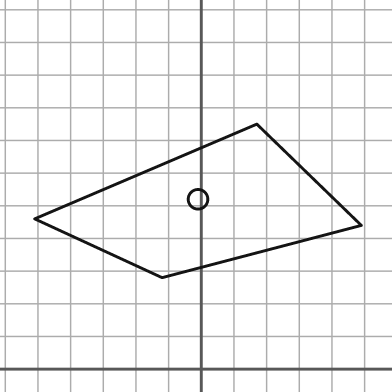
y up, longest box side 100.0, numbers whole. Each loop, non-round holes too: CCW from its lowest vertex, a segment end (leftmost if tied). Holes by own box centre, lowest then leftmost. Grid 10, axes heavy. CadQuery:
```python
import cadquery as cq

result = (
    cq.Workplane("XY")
    .moveTo(-12.0, 28.0)
    .lineTo(49.0, 44.0)
    .lineTo(17.0, 75.0)
    .lineTo(-51.0, 46.0)
    .close()
    .moveTo(-1.0, 52.0)
    .circle(3.0)
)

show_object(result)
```